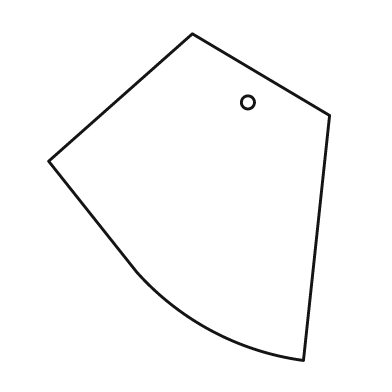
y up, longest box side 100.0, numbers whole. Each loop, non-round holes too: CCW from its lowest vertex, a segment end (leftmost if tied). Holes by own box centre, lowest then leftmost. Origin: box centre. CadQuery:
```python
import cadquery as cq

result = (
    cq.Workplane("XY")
    .moveTo(35.0, -50.0)
    .lineTo(43.0, 25.0)
    .lineTo(1.0, 50.0)
    .lineTo(-43.0, 11.0)
    .lineTo(-16.0, -23.0)
    .threePointArc((7.0, -41.0), (35.0, -50.0))
    .close()
    .moveTo(18.0, 29.0)
    .circle(2.0)
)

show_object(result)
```